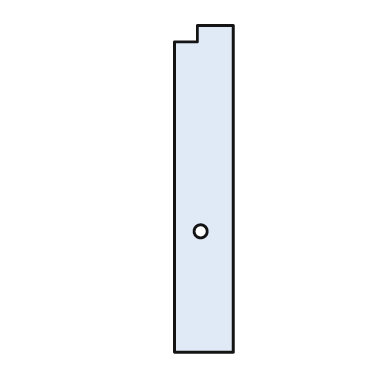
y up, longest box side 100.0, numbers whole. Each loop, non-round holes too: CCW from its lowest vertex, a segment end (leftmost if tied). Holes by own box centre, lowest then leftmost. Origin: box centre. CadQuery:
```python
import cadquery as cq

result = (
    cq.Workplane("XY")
    .moveTo(-9.0, -50.0)
    .lineTo(9.0, -50.0)
    .lineTo(9.0, 50.0)
    .lineTo(-2.0, 50.0)
    .lineTo(-2.0, 45.0)
    .lineTo(-9.0, 45.0)
    .close()
    .moveTo(-1.0, -13.0)
    .circle(2.0)
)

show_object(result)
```